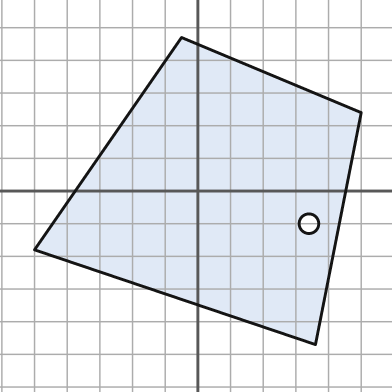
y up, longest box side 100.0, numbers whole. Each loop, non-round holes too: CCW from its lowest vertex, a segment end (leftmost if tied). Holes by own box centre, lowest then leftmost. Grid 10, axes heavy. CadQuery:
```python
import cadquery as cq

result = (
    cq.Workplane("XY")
    .moveTo(36.0, -47.0)
    .lineTo(50.0, 24.0)
    .lineTo(-5.0, 47.0)
    .lineTo(-50.0, -18.0)
    .close()
    .moveTo(34.0, -10.0)
    .circle(3.0)
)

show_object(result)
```